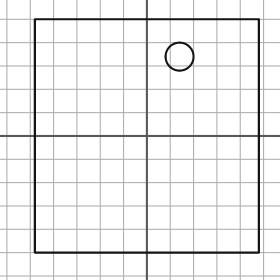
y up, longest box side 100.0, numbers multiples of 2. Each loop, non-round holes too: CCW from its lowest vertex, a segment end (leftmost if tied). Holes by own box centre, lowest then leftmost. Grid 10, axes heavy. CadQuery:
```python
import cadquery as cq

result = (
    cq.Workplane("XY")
    .moveTo(-48.0, -50.0)
    .lineTo(48.0, -50.0)
    .lineTo(48.0, 50.0)
    .lineTo(-48.0, 50.0)
    .close()
    .moveTo(14.0, 34.0)
    .circle(6.0)
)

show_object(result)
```